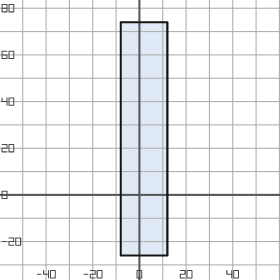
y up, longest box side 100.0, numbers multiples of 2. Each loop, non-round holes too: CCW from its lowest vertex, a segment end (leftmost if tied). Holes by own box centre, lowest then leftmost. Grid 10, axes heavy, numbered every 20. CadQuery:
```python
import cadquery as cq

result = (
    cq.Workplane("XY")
    .moveTo(-8.0, -26.0)
    .lineTo(12.0, -26.0)
    .lineTo(12.0, 74.0)
    .lineTo(-8.0, 74.0)
    .close()
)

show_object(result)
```